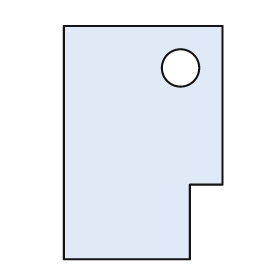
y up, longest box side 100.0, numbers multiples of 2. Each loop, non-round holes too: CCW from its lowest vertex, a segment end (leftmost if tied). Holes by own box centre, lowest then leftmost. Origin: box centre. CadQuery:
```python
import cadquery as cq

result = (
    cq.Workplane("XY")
    .moveTo(-34.0, -50.0)
    .lineTo(20.0, -50.0)
    .lineTo(20.0, -18.0)
    .lineTo(34.0, -18.0)
    .lineTo(34.0, 50.0)
    .lineTo(-34.0, 50.0)
    .close()
    .moveTo(16.0, 32.0)
    .circle(8.0)
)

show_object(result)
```